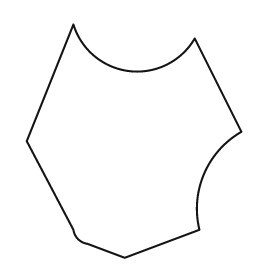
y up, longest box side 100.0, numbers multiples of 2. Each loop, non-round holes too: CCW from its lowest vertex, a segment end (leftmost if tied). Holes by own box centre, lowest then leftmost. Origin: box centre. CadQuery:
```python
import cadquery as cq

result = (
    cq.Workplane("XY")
    .moveTo(-4.0, -50.0)
    .lineTo(28.0, -38.0)
    .threePointArc((30.0, -14.0), (46.0, 4.0))
    .lineTo(26.0, 44.0)
    .threePointArc((-2.0, 30.0), (-26.0, 50.0))
    .lineTo(-46.0, 0.0)
    .lineTo(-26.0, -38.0)
    .threePointArc((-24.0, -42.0), (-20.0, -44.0))
    .close()
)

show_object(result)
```